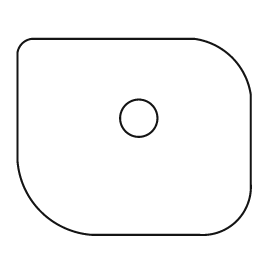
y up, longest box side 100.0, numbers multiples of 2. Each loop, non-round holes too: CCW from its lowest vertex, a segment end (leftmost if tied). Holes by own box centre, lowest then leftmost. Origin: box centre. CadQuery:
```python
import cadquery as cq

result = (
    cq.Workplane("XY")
    .moveTo(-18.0, -42.0)
    .lineTo(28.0, -42.0)
    .threePointArc((44.0, -36.0), (50.0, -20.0))
    .lineTo(50.0, 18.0)
    .threePointArc((42.0, 34.0), (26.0, 42.0))
    .lineTo(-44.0, 42.0)
    .threePointArc((-48.0, 40.0), (-50.0, 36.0))
    .lineTo(-50.0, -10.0)
    .threePointArc((-40.0, -32.0), (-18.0, -42.0))
    .close()
    .moveTo(2.0, 8.0)
    .circle(8.0)
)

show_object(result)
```